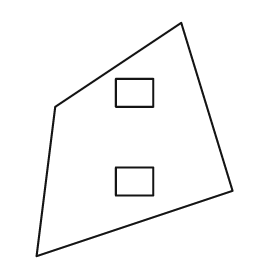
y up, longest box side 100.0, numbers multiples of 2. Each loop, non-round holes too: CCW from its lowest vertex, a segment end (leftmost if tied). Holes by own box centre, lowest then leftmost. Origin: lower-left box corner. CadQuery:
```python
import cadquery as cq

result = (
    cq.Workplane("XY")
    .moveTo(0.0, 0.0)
    .lineTo(84.0, 28.0)
    .lineTo(62.0, 100.0)
    .lineTo(8.0, 64.0)
    .close()
    .moveTo(34.0, 26.0)
    .lineTo(50.0, 26.0)
    .lineTo(50.0, 38.0)
    .lineTo(34.0, 38.0)
    .close()
    .moveTo(34.0, 64.0)
    .lineTo(50.0, 64.0)
    .lineTo(50.0, 76.0)
    .lineTo(34.0, 76.0)
    .close()
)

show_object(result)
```